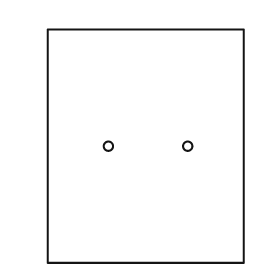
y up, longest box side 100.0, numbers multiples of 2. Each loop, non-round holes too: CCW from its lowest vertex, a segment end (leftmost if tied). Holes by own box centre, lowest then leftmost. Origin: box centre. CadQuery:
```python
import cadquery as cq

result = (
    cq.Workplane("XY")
    .moveTo(-42.0, -50.0)
    .lineTo(42.0, -50.0)
    .lineTo(42.0, 50.0)
    .lineTo(-42.0, 50.0)
    .close()
    .moveTo(-16.0, 0.0)
    .circle(2.0)
    .moveTo(18.0, 0.0)
    .circle(2.0)
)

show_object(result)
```